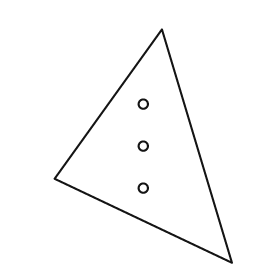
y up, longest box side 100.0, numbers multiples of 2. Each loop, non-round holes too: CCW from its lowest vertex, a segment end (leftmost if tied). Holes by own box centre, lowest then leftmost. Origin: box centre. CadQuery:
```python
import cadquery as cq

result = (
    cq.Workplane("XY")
    .moveTo(38.0, -50.0)
    .lineTo(8.0, 50.0)
    .lineTo(-38.0, -14.0)
    .close()
    .moveTo(0.0, -18.0)
    .circle(2.0)
    .moveTo(0.0, 0.0)
    .circle(2.0)
    .moveTo(0.0, 18.0)
    .circle(2.0)
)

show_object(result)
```